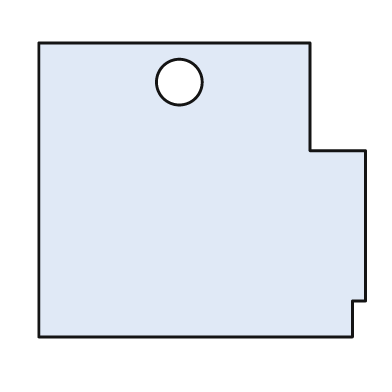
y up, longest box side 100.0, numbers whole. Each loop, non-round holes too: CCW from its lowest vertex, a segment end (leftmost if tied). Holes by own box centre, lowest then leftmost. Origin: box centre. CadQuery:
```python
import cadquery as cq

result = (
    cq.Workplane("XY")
    .moveTo(-50.0, -45.0)
    .lineTo(46.0, -45.0)
    .lineTo(46.0, -34.0)
    .lineTo(50.0, -34.0)
    .lineTo(50.0, 12.0)
    .lineTo(33.0, 12.0)
    .lineTo(33.0, 45.0)
    .lineTo(-50.0, 45.0)
    .close()
    .moveTo(-7.0, 33.0)
    .circle(7.0)
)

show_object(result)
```